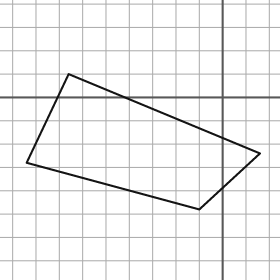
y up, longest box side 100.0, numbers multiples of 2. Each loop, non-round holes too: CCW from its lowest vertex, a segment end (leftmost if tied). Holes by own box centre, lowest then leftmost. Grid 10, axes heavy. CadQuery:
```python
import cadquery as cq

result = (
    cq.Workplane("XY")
    .moveTo(-10.0, -48.0)
    .lineTo(16.0, -24.0)
    .lineTo(-66.0, 10.0)
    .lineTo(-84.0, -28.0)
    .close()
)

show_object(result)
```